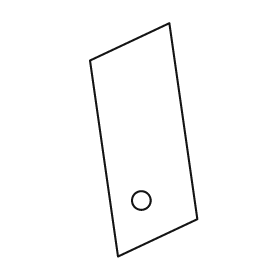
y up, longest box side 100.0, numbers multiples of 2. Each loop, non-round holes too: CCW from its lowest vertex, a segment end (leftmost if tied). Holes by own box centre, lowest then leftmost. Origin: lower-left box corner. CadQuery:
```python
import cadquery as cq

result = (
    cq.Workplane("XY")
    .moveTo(12.0, 0.0)
    .lineTo(46.0, 16.0)
    .lineTo(34.0, 100.0)
    .lineTo(0.0, 84.0)
    .close()
    .moveTo(22.0, 24.0)
    .circle(4.0)
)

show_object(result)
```